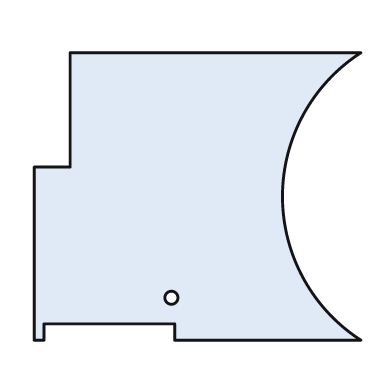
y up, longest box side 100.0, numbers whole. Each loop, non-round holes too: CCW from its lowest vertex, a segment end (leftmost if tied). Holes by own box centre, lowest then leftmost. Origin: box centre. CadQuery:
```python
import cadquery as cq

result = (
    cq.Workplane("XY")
    .moveTo(-50.0, -44.0)
    .lineTo(-47.0, -44.0)
    .lineTo(-47.0, -39.0)
    .lineTo(-7.0, -39.0)
    .lineTo(-7.0, -44.0)
    .lineTo(50.0, -44.0)
    .threePointArc((26.0, 0.0), (50.0, 44.0))
    .lineTo(-39.0, 44.0)
    .lineTo(-39.0, 9.0)
    .lineTo(-50.0, 9.0)
    .close()
    .moveTo(-8.0, -31.0)
    .circle(2.0)
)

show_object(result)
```